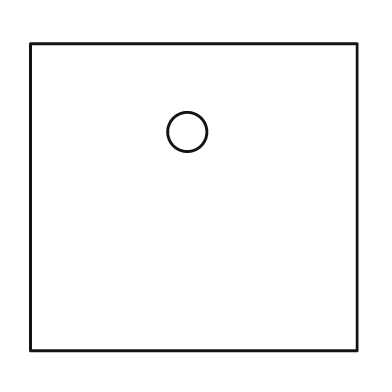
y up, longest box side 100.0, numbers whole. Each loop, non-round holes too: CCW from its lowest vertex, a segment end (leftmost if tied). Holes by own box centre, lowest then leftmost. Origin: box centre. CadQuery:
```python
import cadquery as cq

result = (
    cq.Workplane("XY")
    .moveTo(-50.0, -47.0)
    .lineTo(50.0, -47.0)
    .lineTo(50.0, 47.0)
    .lineTo(-50.0, 47.0)
    .close()
    .moveTo(-2.0, 20.0)
    .circle(6.0)
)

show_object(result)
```